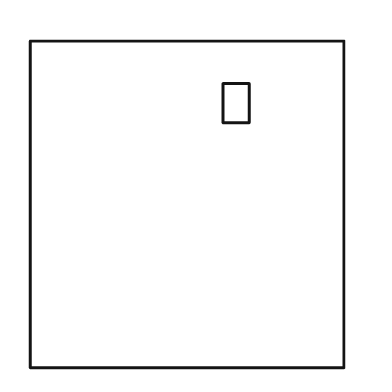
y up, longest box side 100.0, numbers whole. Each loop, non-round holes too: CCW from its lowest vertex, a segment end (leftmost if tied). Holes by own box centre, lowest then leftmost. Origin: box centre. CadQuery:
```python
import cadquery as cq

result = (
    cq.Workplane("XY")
    .moveTo(-48.0, -50.0)
    .lineTo(48.0, -50.0)
    .lineTo(48.0, 50.0)
    .lineTo(-48.0, 50.0)
    .close()
    .moveTo(11.0, 25.0)
    .lineTo(19.0, 25.0)
    .lineTo(19.0, 37.0)
    .lineTo(11.0, 37.0)
    .close()
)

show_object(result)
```